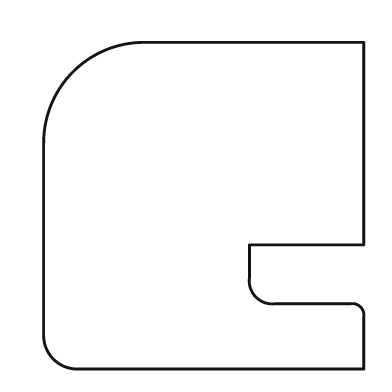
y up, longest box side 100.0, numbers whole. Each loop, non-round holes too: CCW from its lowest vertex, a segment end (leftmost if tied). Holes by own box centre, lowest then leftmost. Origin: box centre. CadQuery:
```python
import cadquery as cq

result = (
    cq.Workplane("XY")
    .moveTo(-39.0, -50.0)
    .lineTo(49.0, -50.0)
    .lineTo(49.0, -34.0)
    .threePointArc((48.0, -31.0), (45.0, -30.0))
    .lineTo(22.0, -30.0)
    .threePointArc((16.0, -28.0), (14.0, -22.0))
    .lineTo(14.0, -12.0)
    .lineTo(49.0, -12.0)
    .lineTo(49.0, 50.0)
    .lineTo(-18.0, 50.0)
    .threePointArc((-40.0, 41.0), (-49.0, 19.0))
    .lineTo(-49.0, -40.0)
    .threePointArc((-46.0, -47.0), (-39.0, -50.0))
    .close()
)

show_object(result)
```